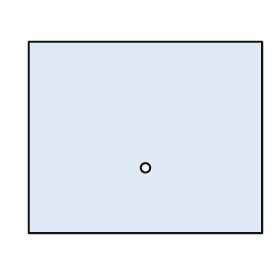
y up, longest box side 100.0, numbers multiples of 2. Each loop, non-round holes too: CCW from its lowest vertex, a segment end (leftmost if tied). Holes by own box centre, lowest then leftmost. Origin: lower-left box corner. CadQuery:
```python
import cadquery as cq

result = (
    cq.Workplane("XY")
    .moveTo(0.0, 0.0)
    .lineTo(100.0, 0.0)
    .lineTo(100.0, 82.0)
    .lineTo(0.0, 82.0)
    .close()
    .moveTo(50.0, 28.0)
    .circle(2.0)
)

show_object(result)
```